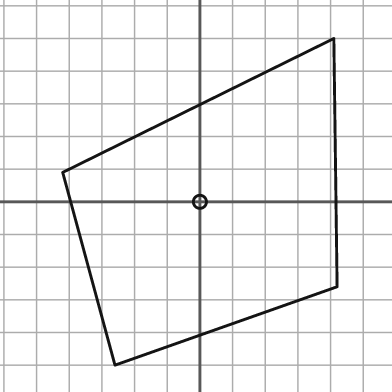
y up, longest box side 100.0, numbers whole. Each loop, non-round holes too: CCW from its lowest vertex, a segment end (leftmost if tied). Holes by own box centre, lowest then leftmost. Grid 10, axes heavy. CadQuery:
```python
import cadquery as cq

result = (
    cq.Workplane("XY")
    .moveTo(-26.0, -50.0)
    .lineTo(42.0, -26.0)
    .lineTo(41.0, 50.0)
    .lineTo(-42.0, 9.0)
    .close()
    .moveTo(0.0, 0.0)
    .circle(2.0)
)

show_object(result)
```